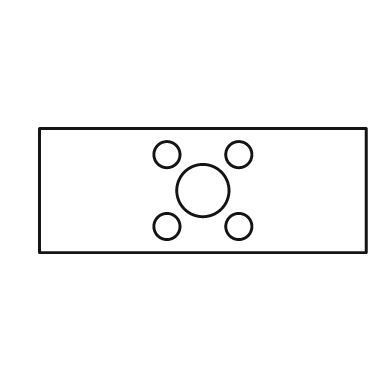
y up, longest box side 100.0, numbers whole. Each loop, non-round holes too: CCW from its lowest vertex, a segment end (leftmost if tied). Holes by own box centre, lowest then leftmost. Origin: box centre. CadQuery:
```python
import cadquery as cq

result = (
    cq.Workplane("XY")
    .moveTo(-50.0, -19.0)
    .lineTo(50.0, -19.0)
    .lineTo(50.0, 19.0)
    .lineTo(-50.0, 19.0)
    .close()
    .moveTo(-11.0, -11.0)
    .circle(4.0)
    .moveTo(11.0, -11.0)
    .circle(4.0)
    .moveTo(0.0, 0.0)
    .circle(8.0)
    .moveTo(-11.0, 11.0)
    .circle(4.0)
    .moveTo(11.0, 11.0)
    .circle(4.0)
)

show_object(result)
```